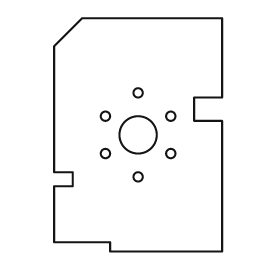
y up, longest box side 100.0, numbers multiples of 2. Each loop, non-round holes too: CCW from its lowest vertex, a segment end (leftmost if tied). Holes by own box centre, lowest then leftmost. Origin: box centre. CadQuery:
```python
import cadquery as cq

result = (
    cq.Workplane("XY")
    .moveTo(-12.0, -50.0)
    .lineTo(36.0, -50.0)
    .lineTo(36.0, 6.0)
    .lineTo(24.0, 6.0)
    .lineTo(24.0, 16.0)
    .lineTo(36.0, 16.0)
    .lineTo(36.0, 50.0)
    .lineTo(-24.0, 50.0)
    .lineTo(-36.0, 38.0)
    .lineTo(-36.0, -16.0)
    .lineTo(-28.0, -16.0)
    .lineTo(-28.0, -22.0)
    .lineTo(-36.0, -22.0)
    .lineTo(-36.0, -46.0)
    .lineTo(-12.0, -46.0)
    .close()
    .moveTo(0.0, -18.0)
    .circle(2.0)
    .moveTo(-14.0, -8.0)
    .circle(2.0)
    .moveTo(14.0, -8.0)
    .circle(2.0)
    .moveTo(0.0, 0.0)
    .circle(8.0)
    .moveTo(-14.0, 8.0)
    .circle(2.0)
    .moveTo(14.0, 8.0)
    .circle(2.0)
    .moveTo(0.0, 18.0)
    .circle(2.0)
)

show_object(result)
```